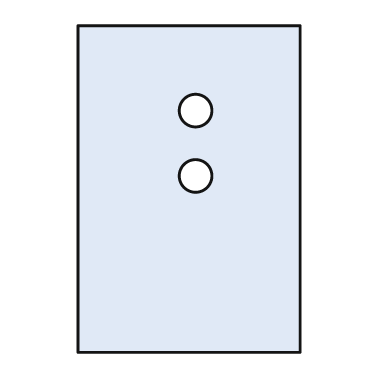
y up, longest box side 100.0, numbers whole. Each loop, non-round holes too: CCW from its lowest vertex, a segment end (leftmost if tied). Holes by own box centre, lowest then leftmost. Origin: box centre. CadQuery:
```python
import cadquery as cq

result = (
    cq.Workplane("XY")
    .moveTo(-34.0, -50.0)
    .lineTo(34.0, -50.0)
    .lineTo(34.0, 50.0)
    .lineTo(-34.0, 50.0)
    .close()
    .moveTo(2.0, 4.0)
    .circle(5.0)
    .moveTo(2.0, 24.0)
    .circle(5.0)
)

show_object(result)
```